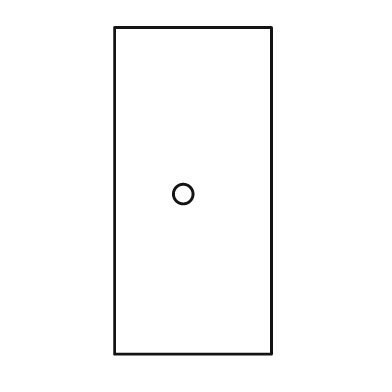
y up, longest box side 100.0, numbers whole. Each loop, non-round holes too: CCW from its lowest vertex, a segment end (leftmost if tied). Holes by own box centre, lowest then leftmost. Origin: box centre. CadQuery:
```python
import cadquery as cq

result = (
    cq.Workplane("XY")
    .moveTo(-24.0, -50.0)
    .lineTo(24.0, -50.0)
    .lineTo(24.0, 50.0)
    .lineTo(-24.0, 50.0)
    .close()
    .moveTo(-3.0, -1.0)
    .circle(3.0)
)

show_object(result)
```